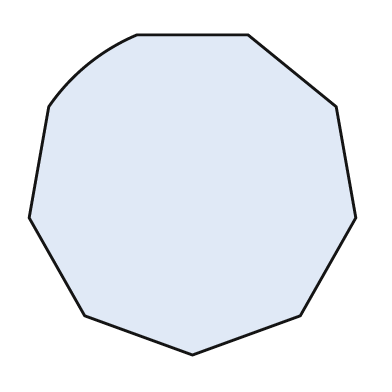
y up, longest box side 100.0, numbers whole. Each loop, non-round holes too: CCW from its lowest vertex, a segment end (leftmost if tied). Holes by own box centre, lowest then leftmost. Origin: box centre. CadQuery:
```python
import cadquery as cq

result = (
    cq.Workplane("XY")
    .moveTo(0.0, -49.0)
    .lineTo(33.0, -37.0)
    .lineTo(50.0, -7.0)
    .lineTo(44.0, 27.0)
    .lineTo(17.0, 49.0)
    .lineTo(-17.0, 49.0)
    .threePointArc((-32.0, 40.0), (-44.0, 27.0))
    .lineTo(-50.0, -7.0)
    .lineTo(-33.0, -37.0)
    .close()
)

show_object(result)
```